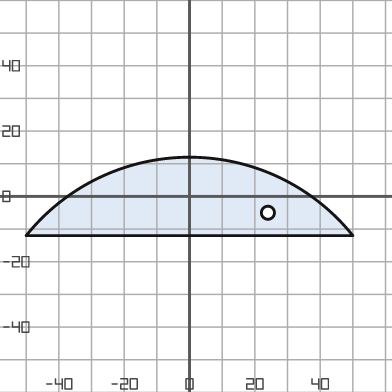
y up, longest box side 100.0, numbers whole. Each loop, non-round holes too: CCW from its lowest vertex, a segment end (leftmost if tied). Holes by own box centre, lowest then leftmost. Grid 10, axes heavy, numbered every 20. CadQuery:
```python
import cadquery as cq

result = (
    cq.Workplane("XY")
    .moveTo(-50.0, -12.0)
    .lineTo(50.0, -12.0)
    .threePointArc((0.0, 12.0), (-50.0, -12.0))
    .close()
    .moveTo(24.0, -5.0)
    .circle(2.0)
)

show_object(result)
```